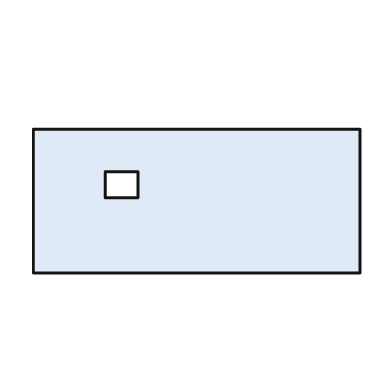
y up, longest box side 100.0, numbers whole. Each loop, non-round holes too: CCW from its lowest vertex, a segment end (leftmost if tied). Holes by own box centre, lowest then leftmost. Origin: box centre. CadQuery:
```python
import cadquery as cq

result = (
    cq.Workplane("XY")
    .moveTo(-50.0, -22.0)
    .lineTo(50.0, -22.0)
    .lineTo(50.0, 22.0)
    .lineTo(-50.0, 22.0)
    .close()
    .moveTo(-28.0, 1.0)
    .lineTo(-18.0, 1.0)
    .lineTo(-18.0, 9.0)
    .lineTo(-28.0, 9.0)
    .close()
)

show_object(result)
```